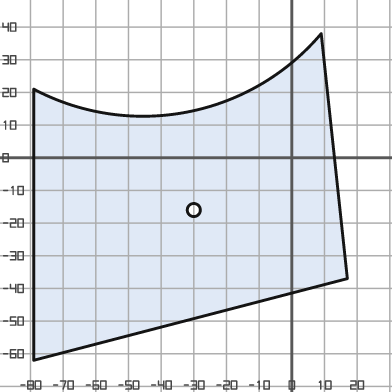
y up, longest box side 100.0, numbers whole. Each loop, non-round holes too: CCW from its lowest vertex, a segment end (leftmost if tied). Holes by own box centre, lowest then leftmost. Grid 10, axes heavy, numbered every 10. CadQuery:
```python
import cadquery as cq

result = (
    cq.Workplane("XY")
    .moveTo(-79.0, -62.0)
    .lineTo(17.0, -37.0)
    .lineTo(9.0, 38.0)
    .threePointArc((-32.0, 14.0), (-79.0, 21.0))
    .close()
    .moveTo(-30.0, -16.0)
    .circle(2.0)
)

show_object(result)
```